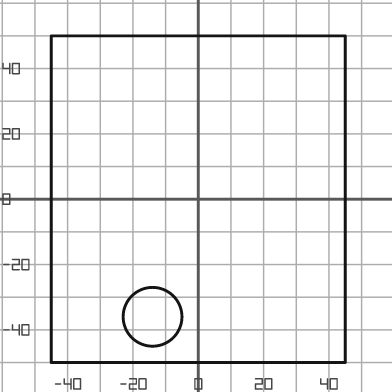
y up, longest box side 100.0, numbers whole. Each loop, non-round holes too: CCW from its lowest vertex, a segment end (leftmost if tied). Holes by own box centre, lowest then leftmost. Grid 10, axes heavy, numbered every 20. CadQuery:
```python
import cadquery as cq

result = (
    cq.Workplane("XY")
    .moveTo(-45.0, -50.0)
    .lineTo(45.0, -50.0)
    .lineTo(45.0, 50.0)
    .lineTo(-45.0, 50.0)
    .close()
    .moveTo(-14.0, -36.0)
    .circle(9.0)
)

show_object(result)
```